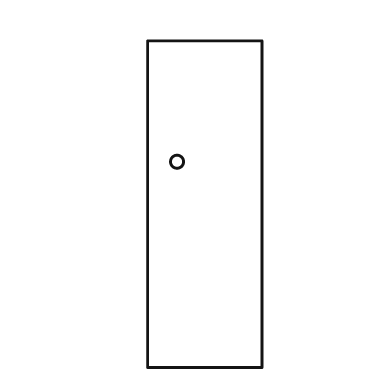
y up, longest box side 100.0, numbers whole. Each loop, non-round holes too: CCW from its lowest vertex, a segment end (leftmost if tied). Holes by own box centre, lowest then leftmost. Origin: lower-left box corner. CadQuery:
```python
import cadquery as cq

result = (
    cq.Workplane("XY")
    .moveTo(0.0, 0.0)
    .lineTo(35.0, 0.0)
    .lineTo(35.0, 100.0)
    .lineTo(0.0, 100.0)
    .close()
    .moveTo(9.0, 63.0)
    .circle(2.0)
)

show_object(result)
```